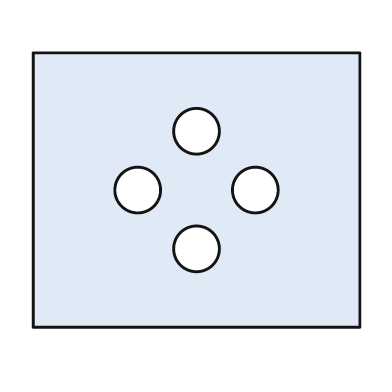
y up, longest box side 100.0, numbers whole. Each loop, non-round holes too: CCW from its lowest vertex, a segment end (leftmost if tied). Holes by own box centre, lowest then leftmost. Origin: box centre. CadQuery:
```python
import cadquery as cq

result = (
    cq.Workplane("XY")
    .moveTo(-50.0, -42.0)
    .lineTo(50.0, -42.0)
    .lineTo(50.0, 42.0)
    .lineTo(-50.0, 42.0)
    .close()
    .moveTo(0.0, -18.0)
    .circle(7.0)
    .moveTo(-18.0, 0.0)
    .circle(7.0)
    .moveTo(18.0, 0.0)
    .circle(7.0)
    .moveTo(0.0, 18.0)
    .circle(7.0)
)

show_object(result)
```